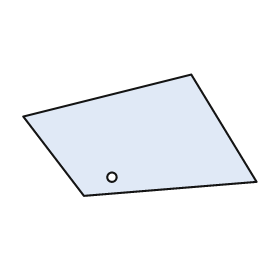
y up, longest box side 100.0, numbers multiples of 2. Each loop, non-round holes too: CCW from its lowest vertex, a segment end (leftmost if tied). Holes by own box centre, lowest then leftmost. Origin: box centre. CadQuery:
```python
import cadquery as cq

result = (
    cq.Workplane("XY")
    .moveTo(-24.0, -26.0)
    .lineTo(50.0, -20.0)
    .lineTo(22.0, 26.0)
    .lineTo(-50.0, 8.0)
    .close()
    .moveTo(-12.0, -18.0)
    .circle(2.0)
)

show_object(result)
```